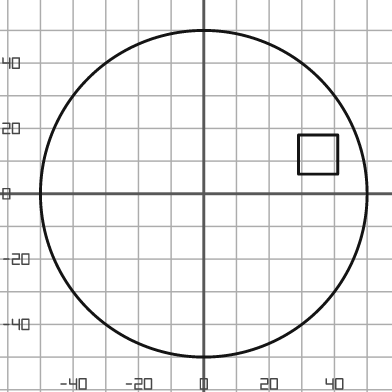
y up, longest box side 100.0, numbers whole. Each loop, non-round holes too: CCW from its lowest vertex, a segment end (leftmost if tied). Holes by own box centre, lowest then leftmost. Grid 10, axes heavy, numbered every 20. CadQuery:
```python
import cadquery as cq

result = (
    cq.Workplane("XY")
    .moveTo(0.0, 0.0)
    .circle(50.0)
    .moveTo(29.0, 6.0)
    .lineTo(41.0, 6.0)
    .lineTo(41.0, 18.0)
    .lineTo(29.0, 18.0)
    .close()
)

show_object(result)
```